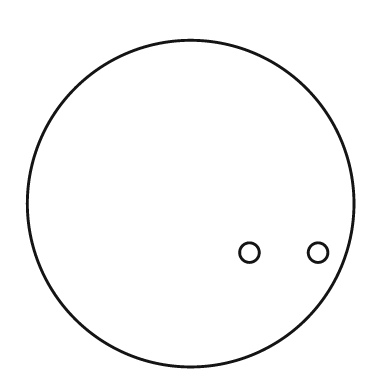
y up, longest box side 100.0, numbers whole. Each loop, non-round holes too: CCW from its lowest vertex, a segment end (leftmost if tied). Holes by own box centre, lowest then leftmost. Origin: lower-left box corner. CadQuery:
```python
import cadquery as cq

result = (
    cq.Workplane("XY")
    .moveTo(50.0, 50.0)
    .circle(50.0)
    .moveTo(68.0, 35.0)
    .circle(3.0)
    .moveTo(89.0, 35.0)
    .circle(3.0)
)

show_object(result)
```